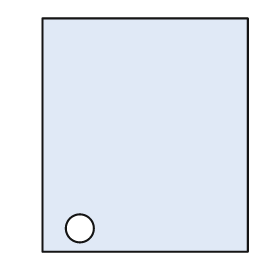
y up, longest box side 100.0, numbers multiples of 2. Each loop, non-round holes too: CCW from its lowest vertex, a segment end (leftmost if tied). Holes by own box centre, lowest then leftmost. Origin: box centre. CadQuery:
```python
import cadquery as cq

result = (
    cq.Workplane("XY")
    .moveTo(-44.0, -50.0)
    .lineTo(44.0, -50.0)
    .lineTo(44.0, 50.0)
    .lineTo(-44.0, 50.0)
    .close()
    .moveTo(-28.0, -40.0)
    .circle(6.0)
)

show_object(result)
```